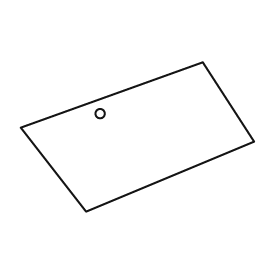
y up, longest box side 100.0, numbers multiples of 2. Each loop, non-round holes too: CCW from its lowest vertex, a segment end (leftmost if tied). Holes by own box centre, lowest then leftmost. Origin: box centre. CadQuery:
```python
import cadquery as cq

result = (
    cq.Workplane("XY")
    .moveTo(-22.0, -32.0)
    .lineTo(50.0, -2.0)
    .lineTo(28.0, 32.0)
    .lineTo(-50.0, 4.0)
    .close()
    .moveTo(-16.0, 10.0)
    .circle(2.0)
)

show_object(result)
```